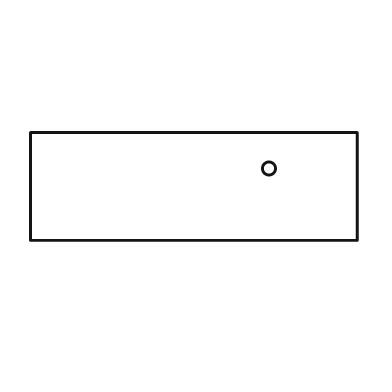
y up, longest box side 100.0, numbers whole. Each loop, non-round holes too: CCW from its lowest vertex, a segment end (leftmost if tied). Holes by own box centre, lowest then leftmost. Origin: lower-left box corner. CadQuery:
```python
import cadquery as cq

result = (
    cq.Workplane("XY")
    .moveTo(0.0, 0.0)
    .lineTo(100.0, 0.0)
    .lineTo(100.0, 33.0)
    .lineTo(0.0, 33.0)
    .close()
    .moveTo(73.0, 22.0)
    .circle(2.0)
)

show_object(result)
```